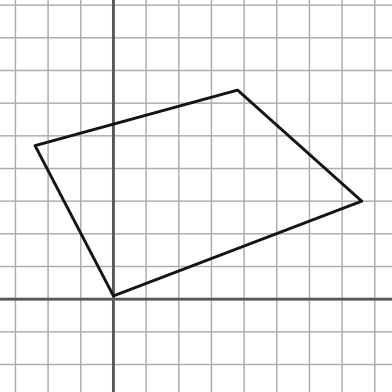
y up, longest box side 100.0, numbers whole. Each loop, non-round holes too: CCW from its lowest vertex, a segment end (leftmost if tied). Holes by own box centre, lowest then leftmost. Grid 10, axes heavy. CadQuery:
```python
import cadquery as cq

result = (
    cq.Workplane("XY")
    .moveTo(0.0, 1.0)
    .lineTo(76.0, 30.0)
    .lineTo(38.0, 64.0)
    .lineTo(-24.0, 47.0)
    .close()
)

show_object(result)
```